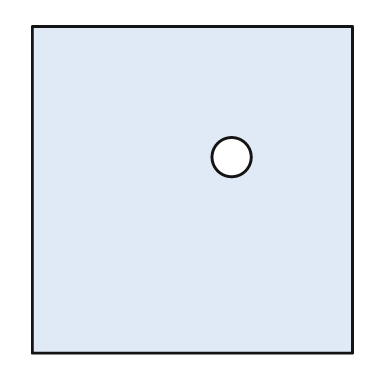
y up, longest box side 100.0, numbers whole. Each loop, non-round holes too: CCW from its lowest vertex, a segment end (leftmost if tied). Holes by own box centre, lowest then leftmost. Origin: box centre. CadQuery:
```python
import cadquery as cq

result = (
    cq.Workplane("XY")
    .moveTo(-49.0, -50.0)
    .lineTo(49.0, -50.0)
    .lineTo(49.0, 50.0)
    .lineTo(-49.0, 50.0)
    .close()
    .moveTo(12.0, 10.0)
    .circle(6.0)
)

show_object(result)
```